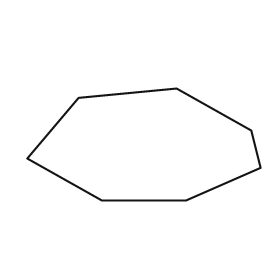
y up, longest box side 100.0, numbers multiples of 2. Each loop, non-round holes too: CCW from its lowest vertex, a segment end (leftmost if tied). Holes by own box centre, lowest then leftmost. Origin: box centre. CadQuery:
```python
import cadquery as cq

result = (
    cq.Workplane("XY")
    .moveTo(-18.0, -24.0)
    .lineTo(18.0, -24.0)
    .lineTo(50.0, -10.0)
    .lineTo(46.0, 6.0)
    .lineTo(14.0, 24.0)
    .lineTo(-28.0, 20.0)
    .lineTo(-50.0, -6.0)
    .close()
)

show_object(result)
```